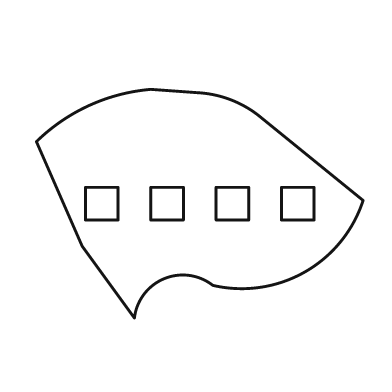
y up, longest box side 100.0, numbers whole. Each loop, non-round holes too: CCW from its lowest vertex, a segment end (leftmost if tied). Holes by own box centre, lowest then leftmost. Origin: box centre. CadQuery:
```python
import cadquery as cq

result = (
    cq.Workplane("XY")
    .moveTo(-20.0, -35.0)
    .threePointArc((-11.0, -23.0), (4.0, -25.0))
    .threePointArc((32.0, -21.0), (50.0, 1.0))
    .lineTo(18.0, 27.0)
    .threePointArc((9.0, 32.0), (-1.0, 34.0))
    .lineTo(-15.0, 35.0)
    .threePointArc((-34.0, 30.0), (-50.0, 19.0))
    .lineTo(-36.0, -13.0)
    .close()
    .moveTo(-35.0, -5.0)
    .lineTo(-25.0, -5.0)
    .lineTo(-25.0, 5.0)
    .lineTo(-35.0, 5.0)
    .close()
    .moveTo(-15.0, -5.0)
    .lineTo(-5.0, -5.0)
    .lineTo(-5.0, 5.0)
    .lineTo(-15.0, 5.0)
    .close()
    .moveTo(5.0, -5.0)
    .lineTo(15.0, -5.0)
    .lineTo(15.0, 5.0)
    .lineTo(5.0, 5.0)
    .close()
    .moveTo(25.0, -5.0)
    .lineTo(35.0, -5.0)
    .lineTo(35.0, 5.0)
    .lineTo(25.0, 5.0)
    .close()
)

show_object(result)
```